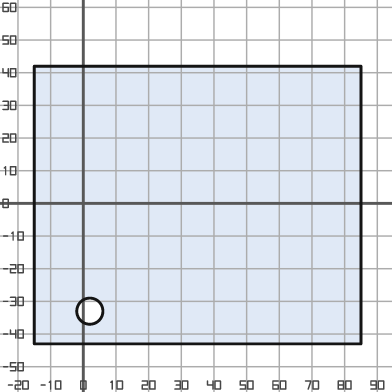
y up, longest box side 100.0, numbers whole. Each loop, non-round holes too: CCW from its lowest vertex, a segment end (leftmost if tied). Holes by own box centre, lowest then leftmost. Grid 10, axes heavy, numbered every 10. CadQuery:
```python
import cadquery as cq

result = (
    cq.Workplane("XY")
    .moveTo(-15.0, -43.0)
    .lineTo(85.0, -43.0)
    .lineTo(85.0, 42.0)
    .lineTo(-15.0, 42.0)
    .close()
    .moveTo(2.0, -33.0)
    .circle(4.0)
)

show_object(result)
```